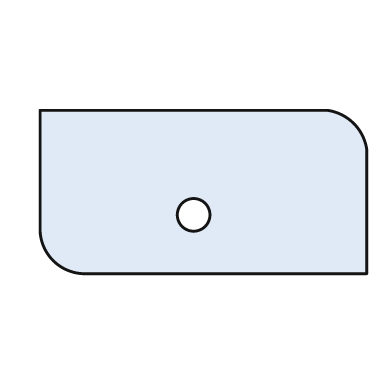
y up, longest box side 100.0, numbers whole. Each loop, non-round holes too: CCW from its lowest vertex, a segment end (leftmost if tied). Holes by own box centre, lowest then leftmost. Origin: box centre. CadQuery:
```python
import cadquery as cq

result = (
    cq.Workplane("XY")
    .moveTo(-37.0, -25.0)
    .lineTo(50.0, -25.0)
    .lineTo(50.0, 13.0)
    .threePointArc((46.0, 21.0), (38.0, 25.0))
    .lineTo(-50.0, 25.0)
    .lineTo(-50.0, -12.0)
    .threePointArc((-46.0, -21.0), (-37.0, -25.0))
    .close()
    .moveTo(-3.0, -7.0)
    .circle(5.0)
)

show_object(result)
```